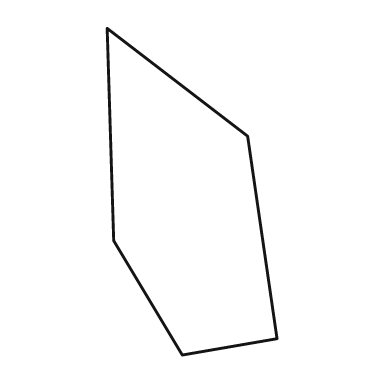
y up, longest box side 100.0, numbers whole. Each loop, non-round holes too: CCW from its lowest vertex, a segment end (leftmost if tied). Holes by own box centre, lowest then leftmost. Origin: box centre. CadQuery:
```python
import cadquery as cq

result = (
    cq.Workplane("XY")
    .moveTo(-3.0, -50.0)
    .lineTo(26.0, -45.0)
    .lineTo(17.0, 17.0)
    .lineTo(-26.0, 50.0)
    .lineTo(-24.0, -15.0)
    .close()
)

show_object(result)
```